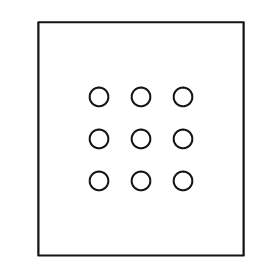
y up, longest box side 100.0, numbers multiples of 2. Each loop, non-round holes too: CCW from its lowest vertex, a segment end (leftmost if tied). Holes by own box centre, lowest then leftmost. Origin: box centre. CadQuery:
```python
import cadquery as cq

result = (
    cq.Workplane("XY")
    .moveTo(-44.0, -50.0)
    .lineTo(44.0, -50.0)
    .lineTo(44.0, 50.0)
    .lineTo(-44.0, 50.0)
    .close()
    .moveTo(-18.0, -18.0)
    .circle(4.0)
    .moveTo(0.0, -18.0)
    .circle(4.0)
    .moveTo(18.0, -18.0)
    .circle(4.0)
    .moveTo(-18.0, 0.0)
    .circle(4.0)
    .moveTo(0.0, 0.0)
    .circle(4.0)
    .moveTo(18.0, 0.0)
    .circle(4.0)
    .moveTo(-18.0, 18.0)
    .circle(4.0)
    .moveTo(0.0, 18.0)
    .circle(4.0)
    .moveTo(18.0, 18.0)
    .circle(4.0)
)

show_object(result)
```